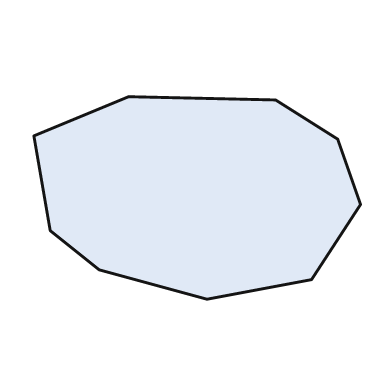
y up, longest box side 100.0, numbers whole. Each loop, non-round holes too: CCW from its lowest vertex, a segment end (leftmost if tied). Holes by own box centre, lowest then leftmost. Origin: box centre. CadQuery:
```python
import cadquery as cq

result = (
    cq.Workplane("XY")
    .moveTo(3.0, -31.0)
    .lineTo(35.0, -25.0)
    .lineTo(50.0, -2.0)
    .lineTo(43.0, 18.0)
    .lineTo(24.0, 30.0)
    .lineTo(-21.0, 31.0)
    .lineTo(-50.0, 19.0)
    .lineTo(-45.0, -10.0)
    .lineTo(-30.0, -22.0)
    .close()
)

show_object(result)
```